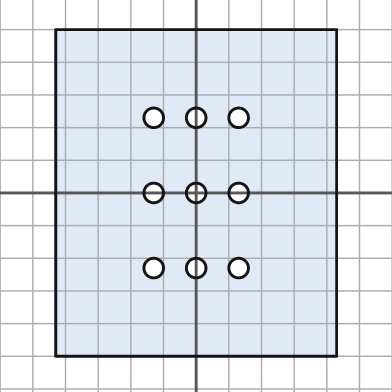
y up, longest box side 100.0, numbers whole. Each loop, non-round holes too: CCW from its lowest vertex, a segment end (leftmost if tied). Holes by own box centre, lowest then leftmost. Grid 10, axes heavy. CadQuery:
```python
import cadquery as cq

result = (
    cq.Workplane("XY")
    .moveTo(-43.0, -50.0)
    .lineTo(43.0, -50.0)
    .lineTo(43.0, 50.0)
    .lineTo(-43.0, 50.0)
    .close()
    .moveTo(-13.0, -23.0)
    .circle(3.0)
    .moveTo(0.0, -23.0)
    .circle(3.0)
    .moveTo(13.0, -23.0)
    .circle(3.0)
    .moveTo(-13.0, 0.0)
    .circle(3.0)
    .moveTo(0.0, 0.0)
    .circle(3.0)
    .moveTo(13.0, 0.0)
    .circle(3.0)
    .moveTo(-13.0, 23.0)
    .circle(3.0)
    .moveTo(0.0, 23.0)
    .circle(3.0)
    .moveTo(13.0, 23.0)
    .circle(3.0)
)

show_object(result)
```